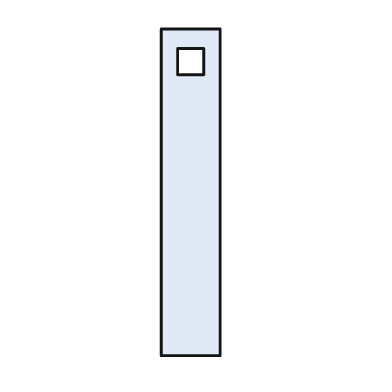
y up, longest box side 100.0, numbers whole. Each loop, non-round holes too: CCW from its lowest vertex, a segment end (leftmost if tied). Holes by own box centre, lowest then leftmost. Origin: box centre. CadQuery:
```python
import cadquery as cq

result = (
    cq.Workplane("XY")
    .moveTo(-9.0, -50.0)
    .lineTo(9.0, -50.0)
    .lineTo(9.0, 50.0)
    .lineTo(-9.0, 50.0)
    .close()
    .moveTo(-4.0, 36.0)
    .lineTo(4.0, 36.0)
    .lineTo(4.0, 44.0)
    .lineTo(-4.0, 44.0)
    .close()
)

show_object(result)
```